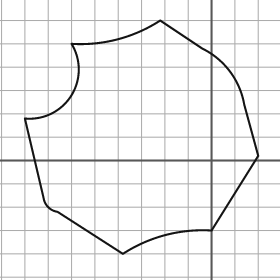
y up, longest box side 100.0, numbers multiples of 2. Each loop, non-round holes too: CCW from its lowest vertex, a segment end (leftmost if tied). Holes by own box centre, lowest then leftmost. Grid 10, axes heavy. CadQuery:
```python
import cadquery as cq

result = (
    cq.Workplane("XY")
    .moveTo(-38.0, -40.0)
    .threePointArc((-20.0, -32.0), (0.0, -30.0))
    .lineTo(20.0, 2.0)
    .lineTo(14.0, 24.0)
    .threePointArc((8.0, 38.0), (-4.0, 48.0))
    .lineTo(-22.0, 60.0)
    .threePointArc((-40.0, 52.0), (-60.0, 50.0))
    .threePointArc((-60.0, 28.0), (-80.0, 18.0))
    .lineTo(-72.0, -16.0)
    .threePointArc((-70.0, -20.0), (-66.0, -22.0))
    .close()
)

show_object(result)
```